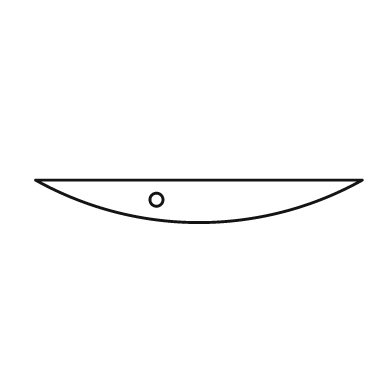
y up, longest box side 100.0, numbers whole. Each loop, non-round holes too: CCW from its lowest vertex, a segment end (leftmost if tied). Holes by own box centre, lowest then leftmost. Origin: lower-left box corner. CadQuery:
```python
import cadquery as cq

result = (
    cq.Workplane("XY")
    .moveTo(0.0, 13.0)
    .threePointArc((50.0, 0.0), (100.0, 13.0))
    .close()
    .moveTo(37.0, 7.0)
    .circle(2.0)
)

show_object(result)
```